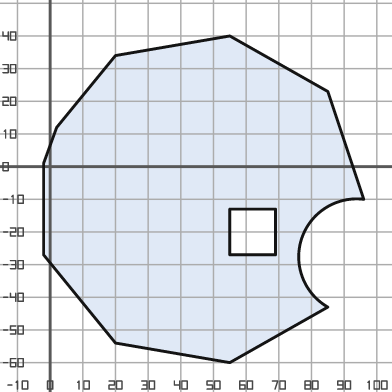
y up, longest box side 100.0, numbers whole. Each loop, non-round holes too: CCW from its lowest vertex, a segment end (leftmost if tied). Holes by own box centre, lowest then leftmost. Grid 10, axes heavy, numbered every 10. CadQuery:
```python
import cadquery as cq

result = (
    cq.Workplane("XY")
    .moveTo(55.0, -60.0)
    .lineTo(85.0, -43.0)
    .threePointArc((77.0, -22.0), (96.0, -10.0))
    .lineTo(85.0, 23.0)
    .lineTo(55.0, 40.0)
    .lineTo(20.0, 34.0)
    .lineTo(2.0, 12.0)
    .lineTo(-2.0, 1.0)
    .lineTo(-2.0, -27.0)
    .lineTo(20.0, -54.0)
    .close()
    .moveTo(55.0, -27.0)
    .lineTo(69.0, -27.0)
    .lineTo(69.0, -13.0)
    .lineTo(55.0, -13.0)
    .close()
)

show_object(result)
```